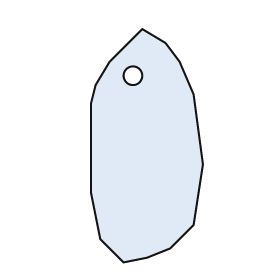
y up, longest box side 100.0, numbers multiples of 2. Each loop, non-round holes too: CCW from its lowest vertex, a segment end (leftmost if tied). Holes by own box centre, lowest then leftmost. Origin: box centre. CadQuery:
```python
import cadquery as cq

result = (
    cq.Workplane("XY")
    .moveTo(-10.0, -50.0)
    .lineTo(0.0, -48.0)
    .lineTo(10.0, -44.0)
    .lineTo(20.0, -34.0)
    .lineTo(24.0, -8.0)
    .lineTo(20.0, 22.0)
    .lineTo(14.0, 36.0)
    .lineTo(8.0, 44.0)
    .lineTo(-2.0, 50.0)
    .lineTo(-16.0, 36.0)
    .lineTo(-22.0, 26.0)
    .lineTo(-24.0, 18.0)
    .lineTo(-24.0, -20.0)
    .lineTo(-20.0, -40.0)
    .close()
    .moveTo(-6.0, 30.0)
    .circle(4.0)
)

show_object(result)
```